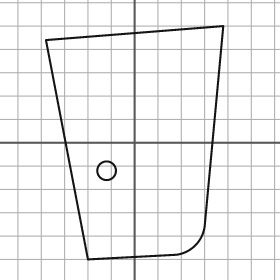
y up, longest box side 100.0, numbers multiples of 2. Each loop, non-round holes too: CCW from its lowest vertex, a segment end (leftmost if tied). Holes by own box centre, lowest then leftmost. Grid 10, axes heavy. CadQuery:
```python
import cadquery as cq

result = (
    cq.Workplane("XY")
    .moveTo(-20.0, -50.0)
    .lineTo(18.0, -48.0)
    .threePointArc((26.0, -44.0), (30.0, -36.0))
    .lineTo(38.0, 50.0)
    .lineTo(-38.0, 44.0)
    .close()
    .moveTo(-12.0, -12.0)
    .circle(4.0)
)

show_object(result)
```